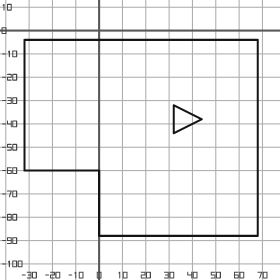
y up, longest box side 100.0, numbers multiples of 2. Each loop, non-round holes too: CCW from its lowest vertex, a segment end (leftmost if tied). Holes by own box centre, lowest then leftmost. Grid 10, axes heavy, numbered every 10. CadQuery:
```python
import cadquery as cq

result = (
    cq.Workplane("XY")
    .moveTo(0.0, -88.0)
    .lineTo(68.0, -88.0)
    .lineTo(68.0, -4.0)
    .lineTo(-32.0, -4.0)
    .lineTo(-32.0, -60.0)
    .lineTo(0.0, -60.0)
    .close()
    .moveTo(32.0, -44.0)
    .lineTo(44.0, -38.0)
    .lineTo(32.0, -32.0)
    .close()
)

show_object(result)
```